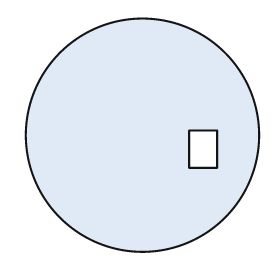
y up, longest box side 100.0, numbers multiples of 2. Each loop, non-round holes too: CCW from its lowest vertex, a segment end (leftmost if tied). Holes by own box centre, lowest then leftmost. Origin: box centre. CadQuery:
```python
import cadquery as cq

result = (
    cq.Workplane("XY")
    .moveTo(0.0, 0.0)
    .circle(50.0)
    .moveTo(20.0, -14.0)
    .lineTo(32.0, -14.0)
    .lineTo(32.0, 2.0)
    .lineTo(20.0, 2.0)
    .close()
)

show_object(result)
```